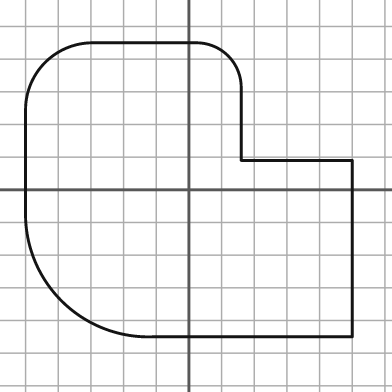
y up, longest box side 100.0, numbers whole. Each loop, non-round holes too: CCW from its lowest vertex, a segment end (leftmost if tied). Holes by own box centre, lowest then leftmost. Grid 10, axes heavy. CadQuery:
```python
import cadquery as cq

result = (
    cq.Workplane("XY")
    .moveTo(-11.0, -45.0)
    .lineTo(50.0, -45.0)
    .lineTo(50.0, 9.0)
    .lineTo(16.0, 9.0)
    .lineTo(16.0, 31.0)
    .threePointArc((12.0, 41.0), (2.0, 45.0))
    .lineTo(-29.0, 45.0)
    .threePointArc((-44.0, 39.0), (-50.0, 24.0))
    .lineTo(-50.0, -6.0)
    .threePointArc((-39.0, -34.0), (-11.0, -45.0))
    .close()
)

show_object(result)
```